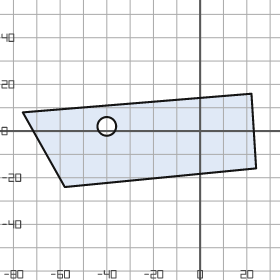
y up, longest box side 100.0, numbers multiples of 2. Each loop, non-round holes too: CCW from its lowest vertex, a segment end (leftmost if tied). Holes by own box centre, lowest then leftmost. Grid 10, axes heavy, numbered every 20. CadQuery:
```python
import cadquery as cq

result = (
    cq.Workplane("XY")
    .moveTo(-58.0, -24.0)
    .lineTo(24.0, -16.0)
    .lineTo(22.0, 16.0)
    .lineTo(-76.0, 8.0)
    .close()
    .moveTo(-40.0, 2.0)
    .circle(4.0)
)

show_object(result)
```